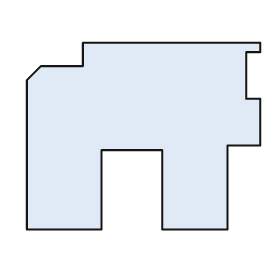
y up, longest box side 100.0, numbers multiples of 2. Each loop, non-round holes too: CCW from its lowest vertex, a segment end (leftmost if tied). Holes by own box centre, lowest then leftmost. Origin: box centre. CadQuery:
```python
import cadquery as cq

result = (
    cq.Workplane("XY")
    .moveTo(-50.0, -40.0)
    .lineTo(-18.0, -40.0)
    .lineTo(-18.0, -6.0)
    .lineTo(8.0, -6.0)
    .lineTo(8.0, -40.0)
    .lineTo(36.0, -40.0)
    .lineTo(36.0, -4.0)
    .lineTo(50.0, -4.0)
    .lineTo(50.0, 16.0)
    .lineTo(44.0, 16.0)
    .lineTo(44.0, 36.0)
    .lineTo(50.0, 36.0)
    .lineTo(50.0, 40.0)
    .lineTo(-26.0, 40.0)
    .lineTo(-26.0, 30.0)
    .lineTo(-44.0, 30.0)
    .lineTo(-50.0, 24.0)
    .close()
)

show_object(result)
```